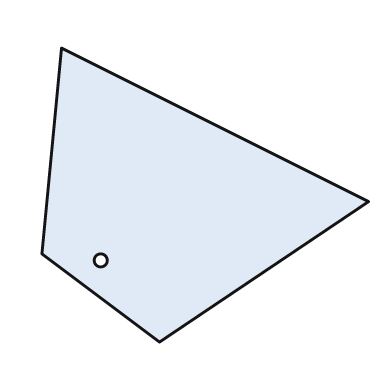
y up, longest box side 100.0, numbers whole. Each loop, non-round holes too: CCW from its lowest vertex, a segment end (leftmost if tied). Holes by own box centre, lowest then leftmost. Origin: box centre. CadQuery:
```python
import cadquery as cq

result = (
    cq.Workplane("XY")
    .moveTo(-14.0, -45.0)
    .lineTo(50.0, -2.0)
    .lineTo(-44.0, 45.0)
    .lineTo(-50.0, -18.0)
    .close()
    .moveTo(-32.0, -20.0)
    .circle(2.0)
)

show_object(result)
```